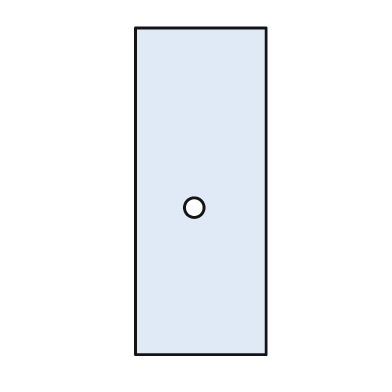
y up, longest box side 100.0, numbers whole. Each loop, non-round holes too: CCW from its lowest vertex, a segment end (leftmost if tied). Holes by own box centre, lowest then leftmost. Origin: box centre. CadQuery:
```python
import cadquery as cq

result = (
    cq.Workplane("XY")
    .moveTo(-20.0, -50.0)
    .lineTo(20.0, -50.0)
    .lineTo(20.0, 50.0)
    .lineTo(-20.0, 50.0)
    .close()
    .moveTo(-2.0, -5.0)
    .circle(3.0)
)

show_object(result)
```